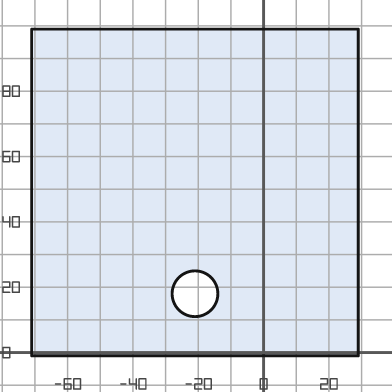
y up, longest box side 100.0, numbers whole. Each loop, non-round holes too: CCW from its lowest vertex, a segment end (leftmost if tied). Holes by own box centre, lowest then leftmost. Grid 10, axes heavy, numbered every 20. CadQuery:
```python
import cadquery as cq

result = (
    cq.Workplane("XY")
    .moveTo(-71.0, -1.0)
    .lineTo(29.0, -1.0)
    .lineTo(29.0, 99.0)
    .lineTo(-71.0, 99.0)
    .close()
    .moveTo(-21.0, 18.0)
    .circle(7.0)
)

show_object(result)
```